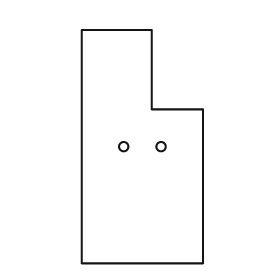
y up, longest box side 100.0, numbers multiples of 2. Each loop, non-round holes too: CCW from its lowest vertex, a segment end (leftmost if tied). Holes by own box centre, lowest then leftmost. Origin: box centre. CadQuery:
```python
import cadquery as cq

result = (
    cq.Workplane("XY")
    .moveTo(-26.0, -50.0)
    .lineTo(26.0, -50.0)
    .lineTo(26.0, 16.0)
    .lineTo(4.0, 16.0)
    .lineTo(4.0, 50.0)
    .lineTo(-26.0, 50.0)
    .close()
    .moveTo(-8.0, 0.0)
    .circle(2.0)
    .moveTo(8.0, 0.0)
    .circle(2.0)
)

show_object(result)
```